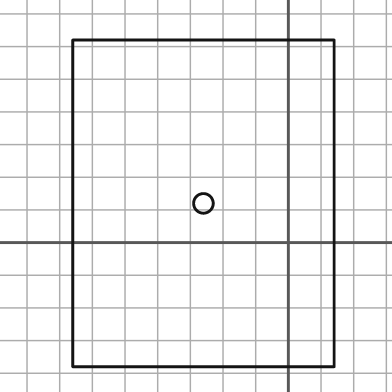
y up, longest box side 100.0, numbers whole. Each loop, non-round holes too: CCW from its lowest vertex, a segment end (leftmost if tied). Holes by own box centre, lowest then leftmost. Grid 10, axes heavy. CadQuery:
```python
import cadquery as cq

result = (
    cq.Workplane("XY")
    .moveTo(-66.0, -38.0)
    .lineTo(14.0, -38.0)
    .lineTo(14.0, 62.0)
    .lineTo(-66.0, 62.0)
    .close()
    .moveTo(-26.0, 12.0)
    .circle(3.0)
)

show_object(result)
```